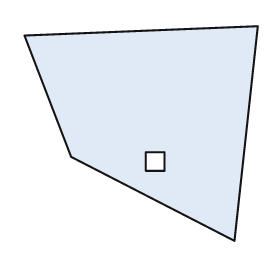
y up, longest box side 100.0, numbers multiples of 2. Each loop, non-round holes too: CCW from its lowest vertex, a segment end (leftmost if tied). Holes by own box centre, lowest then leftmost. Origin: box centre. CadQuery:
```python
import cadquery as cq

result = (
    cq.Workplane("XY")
    .moveTo(40.0, -46.0)
    .lineTo(50.0, 46.0)
    .lineTo(-50.0, 42.0)
    .lineTo(-30.0, -10.0)
    .close()
    .moveTo(2.0, -16.0)
    .lineTo(10.0, -16.0)
    .lineTo(10.0, -8.0)
    .lineTo(2.0, -8.0)
    .close()
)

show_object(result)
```